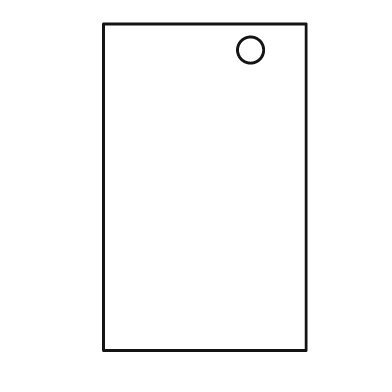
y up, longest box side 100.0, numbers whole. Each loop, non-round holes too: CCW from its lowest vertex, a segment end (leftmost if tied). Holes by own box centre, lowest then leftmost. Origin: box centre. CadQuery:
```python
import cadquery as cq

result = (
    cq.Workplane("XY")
    .moveTo(-31.0, -50.0)
    .lineTo(31.0, -50.0)
    .lineTo(31.0, 50.0)
    .lineTo(-31.0, 50.0)
    .close()
    .moveTo(14.0, 42.0)
    .circle(4.0)
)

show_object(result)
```